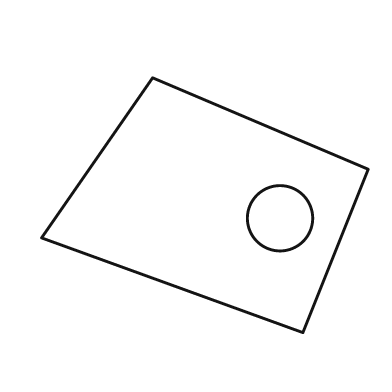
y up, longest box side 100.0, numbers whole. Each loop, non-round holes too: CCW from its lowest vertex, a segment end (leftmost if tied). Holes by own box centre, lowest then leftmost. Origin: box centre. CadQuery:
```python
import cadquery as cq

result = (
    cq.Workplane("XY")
    .moveTo(30.0, -39.0)
    .lineTo(50.0, 11.0)
    .lineTo(-16.0, 39.0)
    .lineTo(-50.0, -10.0)
    .close()
    .moveTo(23.0, -4.0)
    .circle(10.0)
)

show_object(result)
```